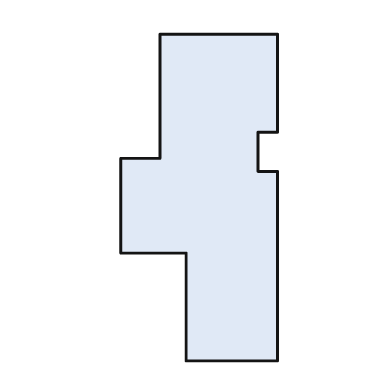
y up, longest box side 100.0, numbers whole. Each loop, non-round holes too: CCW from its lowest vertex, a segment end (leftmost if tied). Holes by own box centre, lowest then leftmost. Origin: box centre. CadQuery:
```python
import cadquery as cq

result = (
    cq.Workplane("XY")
    .moveTo(-4.0, -50.0)
    .lineTo(24.0, -50.0)
    .lineTo(24.0, 8.0)
    .lineTo(18.0, 8.0)
    .lineTo(18.0, 20.0)
    .lineTo(24.0, 20.0)
    .lineTo(24.0, 50.0)
    .lineTo(-12.0, 50.0)
    .lineTo(-12.0, 12.0)
    .lineTo(-24.0, 12.0)
    .lineTo(-24.0, -17.0)
    .lineTo(-4.0, -17.0)
    .close()
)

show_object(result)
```